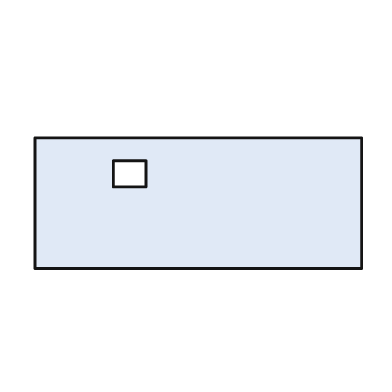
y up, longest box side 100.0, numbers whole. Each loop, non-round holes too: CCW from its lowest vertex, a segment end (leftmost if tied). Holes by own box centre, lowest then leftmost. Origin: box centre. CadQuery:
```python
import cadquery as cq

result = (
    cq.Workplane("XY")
    .moveTo(-50.0, -20.0)
    .lineTo(50.0, -20.0)
    .lineTo(50.0, 20.0)
    .lineTo(-50.0, 20.0)
    .close()
    .moveTo(-26.0, 5.0)
    .lineTo(-16.0, 5.0)
    .lineTo(-16.0, 13.0)
    .lineTo(-26.0, 13.0)
    .close()
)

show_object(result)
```